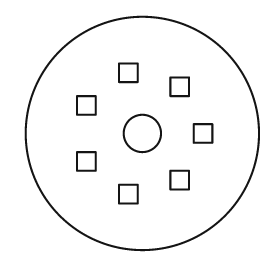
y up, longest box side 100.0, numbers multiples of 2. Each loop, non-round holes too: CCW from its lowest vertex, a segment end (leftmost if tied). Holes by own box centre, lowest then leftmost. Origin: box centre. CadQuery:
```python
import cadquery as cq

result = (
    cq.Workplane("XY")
    .moveTo(0.0, 0.0)
    .circle(50.0)
    .moveTo(-10.0, -30.0)
    .lineTo(-2.0, -30.0)
    .lineTo(-2.0, -22.0)
    .lineTo(-10.0, -22.0)
    .close()
    .moveTo(12.0, -24.0)
    .lineTo(20.0, -24.0)
    .lineTo(20.0, -16.0)
    .lineTo(12.0, -16.0)
    .close()
    .moveTo(-28.0, -16.0)
    .lineTo(-20.0, -16.0)
    .lineTo(-20.0, -8.0)
    .lineTo(-28.0, -8.0)
    .close()
    .moveTo(0.0, 0.0)
    .circle(8.0)
    .moveTo(22.0, -4.0)
    .lineTo(30.0, -4.0)
    .lineTo(30.0, 4.0)
    .lineTo(22.0, 4.0)
    .close()
    .moveTo(-28.0, 8.0)
    .lineTo(-20.0, 8.0)
    .lineTo(-20.0, 16.0)
    .lineTo(-28.0, 16.0)
    .close()
    .moveTo(12.0, 16.0)
    .lineTo(20.0, 16.0)
    .lineTo(20.0, 24.0)
    .lineTo(12.0, 24.0)
    .close()
    .moveTo(-10.0, 22.0)
    .lineTo(-2.0, 22.0)
    .lineTo(-2.0, 30.0)
    .lineTo(-10.0, 30.0)
    .close()
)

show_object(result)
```